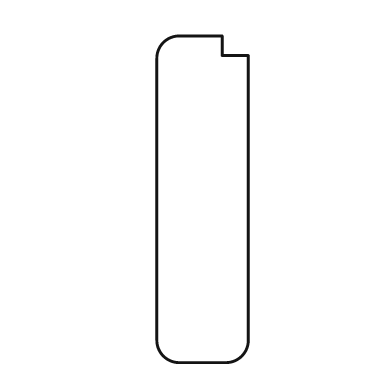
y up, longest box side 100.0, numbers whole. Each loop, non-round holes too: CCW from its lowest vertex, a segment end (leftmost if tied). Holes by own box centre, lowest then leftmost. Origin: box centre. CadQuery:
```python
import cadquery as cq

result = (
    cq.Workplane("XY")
    .moveTo(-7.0, -50.0)
    .lineTo(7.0, -50.0)
    .threePointArc((12.0, -48.0), (14.0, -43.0))
    .lineTo(14.0, 44.0)
    .lineTo(6.0, 44.0)
    .lineTo(6.0, 50.0)
    .lineTo(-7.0, 50.0)
    .threePointArc((-12.0, 48.0), (-14.0, 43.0))
    .lineTo(-14.0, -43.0)
    .threePointArc((-12.0, -48.0), (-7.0, -50.0))
    .close()
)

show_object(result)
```